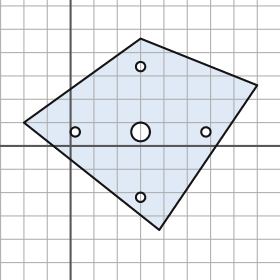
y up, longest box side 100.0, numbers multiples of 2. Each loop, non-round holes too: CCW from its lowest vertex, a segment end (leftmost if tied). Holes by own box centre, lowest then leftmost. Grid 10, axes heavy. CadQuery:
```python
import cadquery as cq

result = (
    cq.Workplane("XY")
    .moveTo(38.0, -36.0)
    .lineTo(80.0, 26.0)
    .lineTo(30.0, 46.0)
    .lineTo(-20.0, 10.0)
    .close()
    .moveTo(30.0, -22.0)
    .circle(2.0)
    .moveTo(2.0, 6.0)
    .circle(2.0)
    .moveTo(30.0, 6.0)
    .circle(4.0)
    .moveTo(58.0, 6.0)
    .circle(2.0)
    .moveTo(30.0, 34.0)
    .circle(2.0)
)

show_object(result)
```